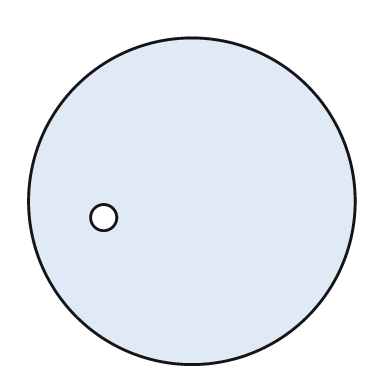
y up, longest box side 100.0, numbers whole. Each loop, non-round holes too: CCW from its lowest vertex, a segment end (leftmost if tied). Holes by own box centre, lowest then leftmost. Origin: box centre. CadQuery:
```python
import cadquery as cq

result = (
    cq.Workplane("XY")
    .moveTo(0.0, 0.0)
    .circle(50.0)
    .moveTo(-27.0, -5.0)
    .circle(4.0)
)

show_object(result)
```